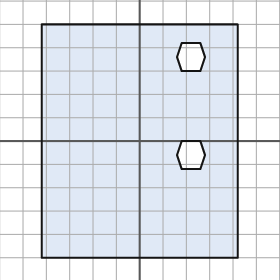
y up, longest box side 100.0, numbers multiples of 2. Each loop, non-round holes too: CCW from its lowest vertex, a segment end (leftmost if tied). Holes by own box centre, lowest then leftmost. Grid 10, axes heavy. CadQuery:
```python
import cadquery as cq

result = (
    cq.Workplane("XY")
    .moveTo(-42.0, -50.0)
    .lineTo(42.0, -50.0)
    .lineTo(42.0, 50.0)
    .lineTo(-42.0, 50.0)
    .close()
    .moveTo(18.0, -12.0)
    .lineTo(26.0, -12.0)
    .lineTo(28.0, -6.0)
    .lineTo(26.0, 0.0)
    .lineTo(18.0, 0.0)
    .lineTo(16.0, -6.0)
    .close()
    .moveTo(18.0, 30.0)
    .lineTo(26.0, 30.0)
    .lineTo(28.0, 36.0)
    .lineTo(26.0, 42.0)
    .lineTo(18.0, 42.0)
    .lineTo(16.0, 36.0)
    .close()
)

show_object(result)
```